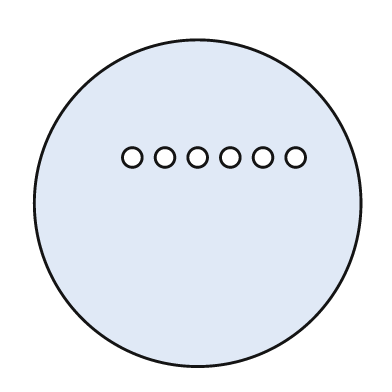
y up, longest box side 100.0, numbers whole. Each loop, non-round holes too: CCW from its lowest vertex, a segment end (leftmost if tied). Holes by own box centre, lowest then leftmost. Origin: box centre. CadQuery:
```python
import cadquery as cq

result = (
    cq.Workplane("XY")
    .moveTo(0.0, 0.0)
    .circle(50.0)
    .moveTo(-20.0, 14.0)
    .circle(3.0)
    .moveTo(-10.0, 14.0)
    .circle(3.0)
    .moveTo(0.0, 14.0)
    .circle(3.0)
    .moveTo(10.0, 14.0)
    .circle(3.0)
    .moveTo(20.0, 14.0)
    .circle(3.0)
    .moveTo(30.0, 14.0)
    .circle(3.0)
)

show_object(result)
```